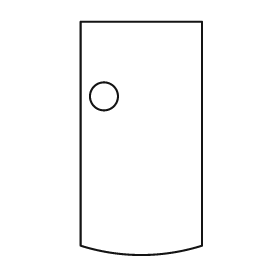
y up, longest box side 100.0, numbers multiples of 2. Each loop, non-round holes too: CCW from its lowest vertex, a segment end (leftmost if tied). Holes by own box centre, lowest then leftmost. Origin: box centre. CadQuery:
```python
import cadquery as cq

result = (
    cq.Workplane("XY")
    .moveTo(-26.0, -46.0)
    .threePointArc((0.0, -50.0), (26.0, -46.0))
    .lineTo(26.0, 50.0)
    .lineTo(-26.0, 50.0)
    .close()
    .moveTo(-16.0, 18.0)
    .circle(6.0)
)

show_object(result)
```